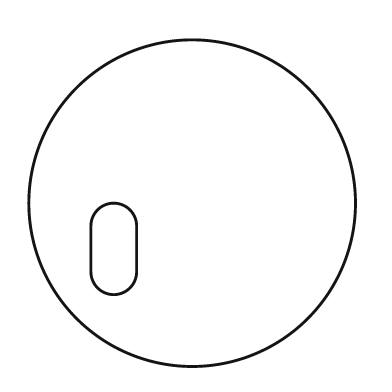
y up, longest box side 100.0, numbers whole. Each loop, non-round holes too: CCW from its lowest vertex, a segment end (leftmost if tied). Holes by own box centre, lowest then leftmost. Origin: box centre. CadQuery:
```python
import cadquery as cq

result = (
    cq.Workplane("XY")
    .moveTo(0.0, 0.0)
    .circle(50.0)
    .moveTo(-31.0, -21.0)
    .threePointArc((-24.0, -28.0), (-17.0, -21.0))
    .lineTo(-17.0, -7.0)
    .threePointArc((-24.0, 0.0), (-31.0, -7.0))
    .close()
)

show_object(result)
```